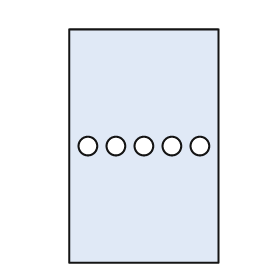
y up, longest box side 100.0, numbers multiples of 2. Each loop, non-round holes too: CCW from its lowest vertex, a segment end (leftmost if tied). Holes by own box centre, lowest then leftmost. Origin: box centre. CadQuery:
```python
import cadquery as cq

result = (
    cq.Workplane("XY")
    .moveTo(-32.0, -50.0)
    .lineTo(32.0, -50.0)
    .lineTo(32.0, 50.0)
    .lineTo(-32.0, 50.0)
    .close()
    .moveTo(-24.0, 0.0)
    .circle(4.0)
    .moveTo(-12.0, 0.0)
    .circle(4.0)
    .moveTo(0.0, 0.0)
    .circle(4.0)
    .moveTo(12.0, 0.0)
    .circle(4.0)
    .moveTo(24.0, 0.0)
    .circle(4.0)
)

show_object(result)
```